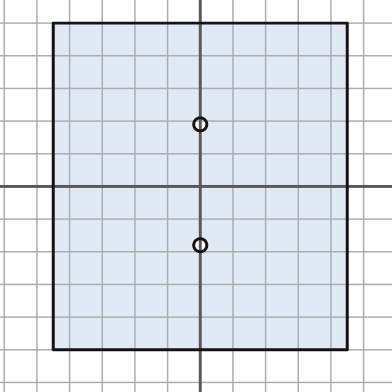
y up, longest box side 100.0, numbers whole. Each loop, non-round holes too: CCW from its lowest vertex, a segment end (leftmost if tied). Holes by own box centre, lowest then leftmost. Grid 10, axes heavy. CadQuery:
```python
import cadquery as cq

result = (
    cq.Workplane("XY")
    .moveTo(-45.0, -50.0)
    .lineTo(45.0, -50.0)
    .lineTo(45.0, 50.0)
    .lineTo(-45.0, 50.0)
    .close()
    .moveTo(0.0, -18.0)
    .circle(2.0)
    .moveTo(0.0, 19.0)
    .circle(2.0)
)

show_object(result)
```